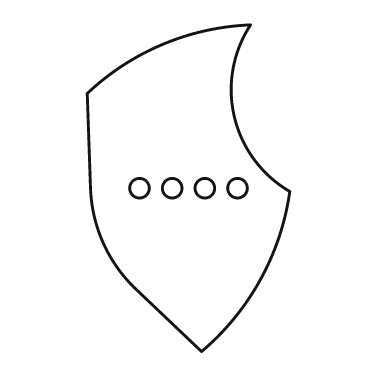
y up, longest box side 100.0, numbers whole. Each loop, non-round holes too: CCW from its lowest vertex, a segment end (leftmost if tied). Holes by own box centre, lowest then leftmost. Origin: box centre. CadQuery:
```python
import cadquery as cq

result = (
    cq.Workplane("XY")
    .moveTo(4.0, -50.0)
    .threePointArc((22.0, -28.0), (31.0, -1.0))
    .threePointArc((14.0, 22.0), (19.0, 50.0))
    .threePointArc((-8.0, 44.0), (-31.0, 29.0))
    .lineTo(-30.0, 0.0)
    .threePointArc((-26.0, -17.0), (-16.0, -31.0))
    .close()
    .moveTo(-15.0, 0.0)
    .circle(3.0)
    .moveTo(-5.0, 0.0)
    .circle(3.0)
    .moveTo(5.0, 0.0)
    .circle(3.0)
    .moveTo(15.0, 0.0)
    .circle(3.0)
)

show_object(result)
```